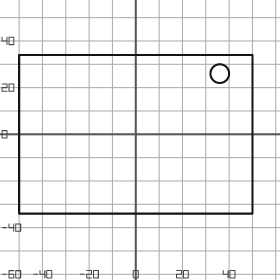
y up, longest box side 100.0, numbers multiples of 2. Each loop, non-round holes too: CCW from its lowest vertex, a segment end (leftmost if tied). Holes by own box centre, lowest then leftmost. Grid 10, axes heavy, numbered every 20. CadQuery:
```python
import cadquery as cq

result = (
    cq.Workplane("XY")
    .moveTo(-50.0, -34.0)
    .lineTo(50.0, -34.0)
    .lineTo(50.0, 34.0)
    .lineTo(-50.0, 34.0)
    .close()
    .moveTo(36.0, 26.0)
    .circle(4.0)
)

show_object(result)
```